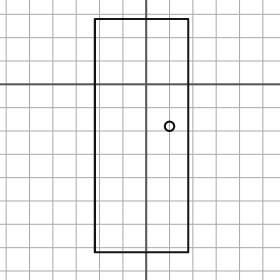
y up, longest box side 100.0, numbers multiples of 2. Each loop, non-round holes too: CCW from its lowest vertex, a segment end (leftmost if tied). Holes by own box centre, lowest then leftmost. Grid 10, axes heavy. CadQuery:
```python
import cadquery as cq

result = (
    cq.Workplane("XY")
    .moveTo(-22.0, -72.0)
    .lineTo(18.0, -72.0)
    .lineTo(18.0, 28.0)
    .lineTo(-22.0, 28.0)
    .close()
    .moveTo(10.0, -18.0)
    .circle(2.0)
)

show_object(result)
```